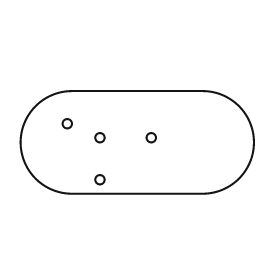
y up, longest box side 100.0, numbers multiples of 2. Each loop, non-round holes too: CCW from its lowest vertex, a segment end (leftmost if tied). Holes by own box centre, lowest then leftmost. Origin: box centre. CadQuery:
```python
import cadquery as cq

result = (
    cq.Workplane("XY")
    .moveTo(-28.0, -22.0)
    .lineTo(28.0, -22.0)
    .threePointArc((50.0, 0.0), (28.0, 22.0))
    .lineTo(-28.0, 22.0)
    .threePointArc((-50.0, 0.0), (-28.0, -22.0))
    .close()
    .moveTo(-16.0, -16.0)
    .circle(2.0)
    .moveTo(-16.0, 2.0)
    .circle(2.0)
    .moveTo(6.0, 2.0)
    .circle(2.0)
    .moveTo(-30.0, 8.0)
    .circle(2.0)
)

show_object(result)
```